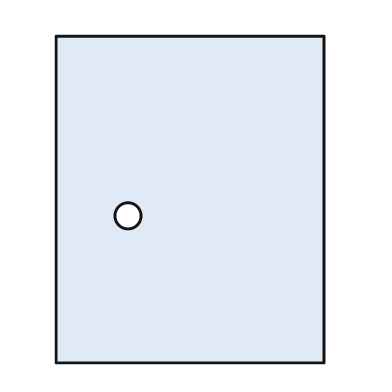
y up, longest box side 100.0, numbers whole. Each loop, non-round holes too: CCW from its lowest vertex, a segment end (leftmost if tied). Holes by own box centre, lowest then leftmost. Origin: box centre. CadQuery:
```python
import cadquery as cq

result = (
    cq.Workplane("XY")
    .moveTo(-41.0, -50.0)
    .lineTo(41.0, -50.0)
    .lineTo(41.0, 50.0)
    .lineTo(-41.0, 50.0)
    .close()
    .moveTo(-19.0, -5.0)
    .circle(4.0)
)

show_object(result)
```